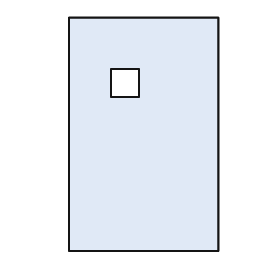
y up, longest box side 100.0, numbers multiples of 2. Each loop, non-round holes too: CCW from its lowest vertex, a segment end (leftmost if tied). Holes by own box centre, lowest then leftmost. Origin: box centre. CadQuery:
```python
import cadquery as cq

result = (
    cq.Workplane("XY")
    .moveTo(-32.0, -50.0)
    .lineTo(32.0, -50.0)
    .lineTo(32.0, 50.0)
    .lineTo(-32.0, 50.0)
    .close()
    .moveTo(-14.0, 16.0)
    .lineTo(-2.0, 16.0)
    .lineTo(-2.0, 28.0)
    .lineTo(-14.0, 28.0)
    .close()
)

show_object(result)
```